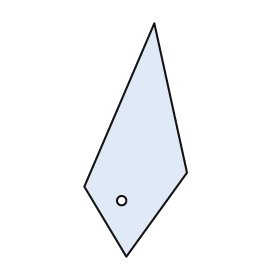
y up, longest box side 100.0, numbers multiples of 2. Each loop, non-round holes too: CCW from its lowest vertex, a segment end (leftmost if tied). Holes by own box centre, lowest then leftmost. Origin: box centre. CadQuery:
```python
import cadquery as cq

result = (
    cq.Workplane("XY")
    .moveTo(-4.0, -50.0)
    .lineTo(22.0, -14.0)
    .lineTo(8.0, 50.0)
    .lineTo(-22.0, -20.0)
    .close()
    .moveTo(-6.0, -26.0)
    .circle(2.0)
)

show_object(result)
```